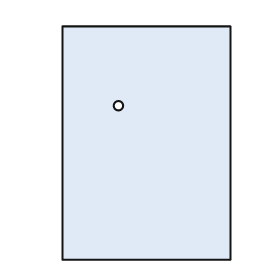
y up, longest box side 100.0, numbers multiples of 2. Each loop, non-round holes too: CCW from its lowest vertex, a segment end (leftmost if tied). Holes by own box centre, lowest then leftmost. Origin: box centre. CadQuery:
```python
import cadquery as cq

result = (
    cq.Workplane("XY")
    .moveTo(-36.0, -50.0)
    .lineTo(36.0, -50.0)
    .lineTo(36.0, 50.0)
    .lineTo(-36.0, 50.0)
    .close()
    .moveTo(-12.0, 16.0)
    .circle(2.0)
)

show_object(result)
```